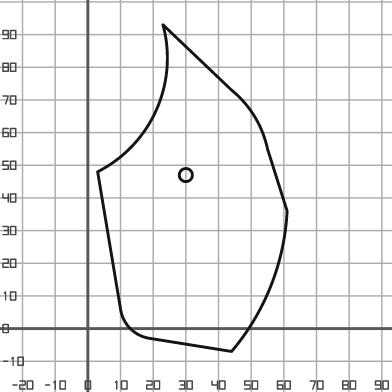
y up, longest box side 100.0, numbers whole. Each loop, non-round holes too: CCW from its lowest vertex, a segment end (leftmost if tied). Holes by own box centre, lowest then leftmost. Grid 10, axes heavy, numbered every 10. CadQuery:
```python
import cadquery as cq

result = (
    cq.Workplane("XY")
    .moveTo(44.0, -7.0)
    .threePointArc((56.0, 13.0), (61.0, 36.0))
    .lineTo(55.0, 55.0)
    .threePointArc((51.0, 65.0), (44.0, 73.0))
    .lineTo(23.0, 93.0)
    .threePointArc((21.0, 67.0), (3.0, 48.0))
    .lineTo(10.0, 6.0)
    .threePointArc((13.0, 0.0), (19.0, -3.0))
    .close()
    .moveTo(30.0, 47.0)
    .circle(2.0)
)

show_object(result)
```